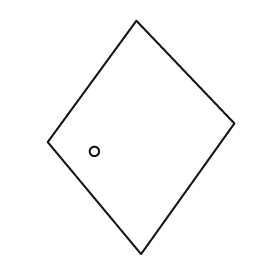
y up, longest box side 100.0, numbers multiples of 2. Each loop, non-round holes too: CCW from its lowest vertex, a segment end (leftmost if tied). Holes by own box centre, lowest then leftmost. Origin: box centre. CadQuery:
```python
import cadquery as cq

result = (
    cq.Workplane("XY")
    .moveTo(0.0, -50.0)
    .lineTo(40.0, 6.0)
    .lineTo(-2.0, 50.0)
    .lineTo(-40.0, -2.0)
    .close()
    .moveTo(-20.0, -6.0)
    .circle(2.0)
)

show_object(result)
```